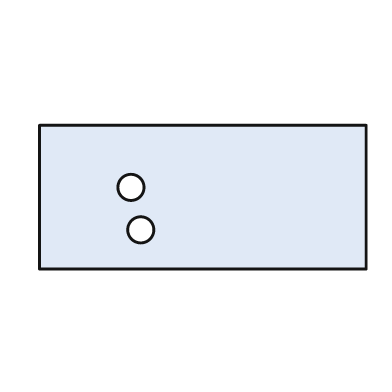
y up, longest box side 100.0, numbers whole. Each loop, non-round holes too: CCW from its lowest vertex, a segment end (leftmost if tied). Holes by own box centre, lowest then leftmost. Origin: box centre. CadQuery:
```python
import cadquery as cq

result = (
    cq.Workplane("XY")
    .moveTo(-50.0, -22.0)
    .lineTo(50.0, -22.0)
    .lineTo(50.0, 22.0)
    .lineTo(-50.0, 22.0)
    .close()
    .moveTo(-19.0, -10.0)
    .circle(4.0)
    .moveTo(-22.0, 3.0)
    .circle(4.0)
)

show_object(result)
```